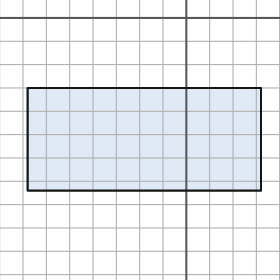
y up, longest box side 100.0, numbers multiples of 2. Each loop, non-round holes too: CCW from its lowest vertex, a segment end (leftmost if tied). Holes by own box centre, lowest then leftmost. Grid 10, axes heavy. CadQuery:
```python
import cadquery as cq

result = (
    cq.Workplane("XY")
    .moveTo(-68.0, -74.0)
    .lineTo(32.0, -74.0)
    .lineTo(32.0, -30.0)
    .lineTo(-68.0, -30.0)
    .close()
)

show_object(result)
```